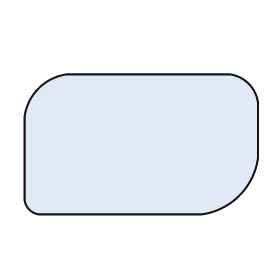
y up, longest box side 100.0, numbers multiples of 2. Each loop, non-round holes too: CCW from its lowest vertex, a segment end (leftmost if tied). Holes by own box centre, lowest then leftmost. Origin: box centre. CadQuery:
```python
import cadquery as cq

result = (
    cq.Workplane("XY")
    .moveTo(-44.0, -30.0)
    .lineTo(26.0, -30.0)
    .threePointArc((42.0, -22.0), (50.0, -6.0))
    .lineTo(50.0, 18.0)
    .threePointArc((46.0, 26.0), (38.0, 30.0))
    .lineTo(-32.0, 30.0)
    .threePointArc((-44.0, 24.0), (-50.0, 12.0))
    .lineTo(-50.0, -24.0)
    .threePointArc((-48.0, -28.0), (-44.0, -30.0))
    .close()
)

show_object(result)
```